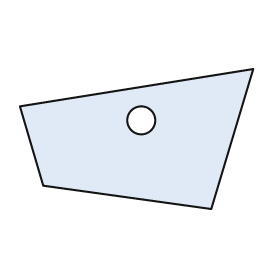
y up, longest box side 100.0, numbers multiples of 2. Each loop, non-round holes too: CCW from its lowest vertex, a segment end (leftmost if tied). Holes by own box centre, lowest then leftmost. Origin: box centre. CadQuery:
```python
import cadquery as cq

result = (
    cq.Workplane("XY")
    .moveTo(32.0, -30.0)
    .lineTo(50.0, 30.0)
    .lineTo(-50.0, 14.0)
    .lineTo(-40.0, -20.0)
    .close()
    .moveTo(2.0, 8.0)
    .circle(6.0)
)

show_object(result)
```